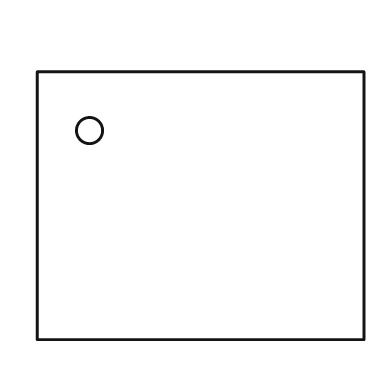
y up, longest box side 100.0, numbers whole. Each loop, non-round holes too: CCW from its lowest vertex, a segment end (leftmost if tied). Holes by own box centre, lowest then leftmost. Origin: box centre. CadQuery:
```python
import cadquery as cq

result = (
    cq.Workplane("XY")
    .moveTo(-50.0, -41.0)
    .lineTo(50.0, -41.0)
    .lineTo(50.0, 41.0)
    .lineTo(-50.0, 41.0)
    .close()
    .moveTo(-34.0, 23.0)
    .circle(4.0)
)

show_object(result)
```